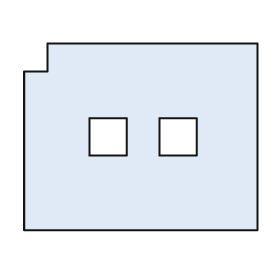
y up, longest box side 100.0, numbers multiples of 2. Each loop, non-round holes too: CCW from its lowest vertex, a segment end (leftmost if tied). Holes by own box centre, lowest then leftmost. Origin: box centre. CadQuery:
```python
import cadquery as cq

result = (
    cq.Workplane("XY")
    .moveTo(-50.0, -40.0)
    .lineTo(50.0, -40.0)
    .lineTo(50.0, 40.0)
    .lineTo(-40.0, 40.0)
    .lineTo(-40.0, 28.0)
    .lineTo(-50.0, 28.0)
    .close()
    .moveTo(-22.0, -8.0)
    .lineTo(-6.0, -8.0)
    .lineTo(-6.0, 8.0)
    .lineTo(-22.0, 8.0)
    .close()
    .moveTo(8.0, -8.0)
    .lineTo(24.0, -8.0)
    .lineTo(24.0, 8.0)
    .lineTo(8.0, 8.0)
    .close()
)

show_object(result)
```